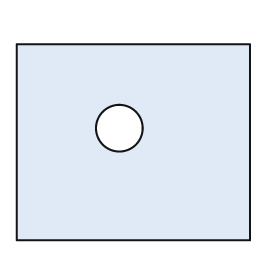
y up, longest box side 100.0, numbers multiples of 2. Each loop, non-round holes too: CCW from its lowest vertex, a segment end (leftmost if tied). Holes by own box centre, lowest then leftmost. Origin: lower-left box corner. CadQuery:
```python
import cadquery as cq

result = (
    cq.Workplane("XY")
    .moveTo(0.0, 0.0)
    .lineTo(100.0, 0.0)
    .lineTo(100.0, 84.0)
    .lineTo(0.0, 84.0)
    .close()
    .moveTo(44.0, 48.0)
    .circle(10.0)
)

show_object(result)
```